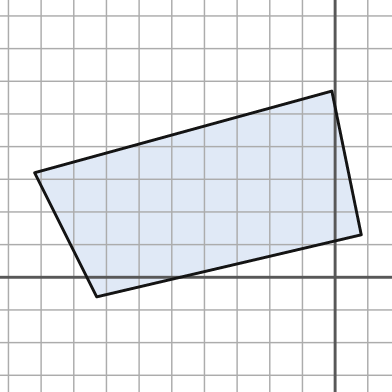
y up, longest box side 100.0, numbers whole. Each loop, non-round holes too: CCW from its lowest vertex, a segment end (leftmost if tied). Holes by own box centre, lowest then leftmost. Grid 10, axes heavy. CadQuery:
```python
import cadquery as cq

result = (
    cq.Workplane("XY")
    .moveTo(-73.0, -6.0)
    .lineTo(8.0, 13.0)
    .lineTo(-1.0, 57.0)
    .lineTo(-92.0, 32.0)
    .close()
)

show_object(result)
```